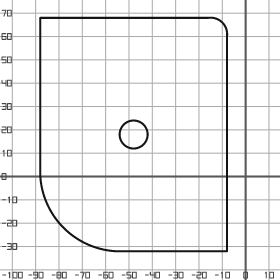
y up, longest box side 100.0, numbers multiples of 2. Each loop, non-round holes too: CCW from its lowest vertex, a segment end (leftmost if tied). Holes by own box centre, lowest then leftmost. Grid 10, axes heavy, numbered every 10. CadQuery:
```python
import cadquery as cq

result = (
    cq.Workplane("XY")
    .moveTo(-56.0, -32.0)
    .lineTo(-8.0, -32.0)
    .lineTo(-8.0, 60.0)
    .threePointArc((-10.0, 66.0), (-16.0, 68.0))
    .lineTo(-88.0, 68.0)
    .lineTo(-88.0, 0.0)
    .threePointArc((-78.0, -22.0), (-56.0, -32.0))
    .close()
    .moveTo(-48.0, 18.0)
    .circle(6.0)
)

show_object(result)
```